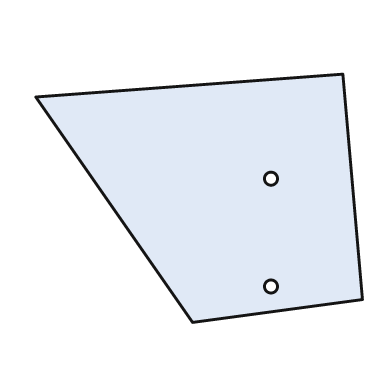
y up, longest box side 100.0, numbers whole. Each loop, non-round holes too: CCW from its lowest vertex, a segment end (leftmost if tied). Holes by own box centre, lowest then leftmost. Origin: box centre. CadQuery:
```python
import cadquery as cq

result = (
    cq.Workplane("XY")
    .moveTo(-2.0, -38.0)
    .lineTo(50.0, -31.0)
    .lineTo(44.0, 38.0)
    .lineTo(-50.0, 31.0)
    .close()
    .moveTo(22.0, -27.0)
    .circle(2.0)
    .moveTo(22.0, 6.0)
    .circle(2.0)
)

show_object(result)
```